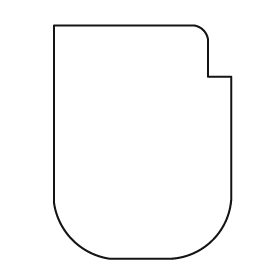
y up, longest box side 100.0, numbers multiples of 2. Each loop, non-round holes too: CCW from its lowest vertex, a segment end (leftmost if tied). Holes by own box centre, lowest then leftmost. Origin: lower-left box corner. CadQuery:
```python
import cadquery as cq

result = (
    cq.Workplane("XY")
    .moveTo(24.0, 0.0)
    .lineTo(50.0, 0.0)
    .threePointArc((68.0, 8.0), (76.0, 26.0))
    .lineTo(76.0, 78.0)
    .lineTo(66.0, 78.0)
    .lineTo(66.0, 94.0)
    .threePointArc((64.0, 98.0), (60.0, 100.0))
    .lineTo(0.0, 100.0)
    .lineTo(0.0, 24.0)
    .threePointArc((8.0, 8.0), (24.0, 0.0))
    .close()
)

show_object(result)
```